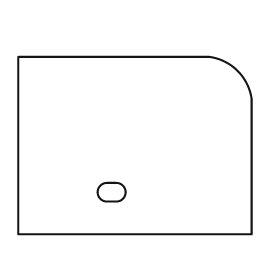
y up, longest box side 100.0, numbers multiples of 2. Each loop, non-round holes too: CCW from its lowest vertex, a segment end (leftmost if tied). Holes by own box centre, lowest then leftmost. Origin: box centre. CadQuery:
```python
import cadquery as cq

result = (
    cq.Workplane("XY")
    .moveTo(-50.0, -38.0)
    .lineTo(50.0, -38.0)
    .lineTo(50.0, 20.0)
    .threePointArc((44.0, 32.0), (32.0, 38.0))
    .lineTo(-50.0, 38.0)
    .close()
    .moveTo(-12.0, -24.0)
    .lineTo(-8.0, -24.0)
    .threePointArc((-4.0, -20.0), (-8.0, -16.0))
    .lineTo(-12.0, -16.0)
    .threePointArc((-16.0, -20.0), (-12.0, -24.0))
    .close()
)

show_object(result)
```